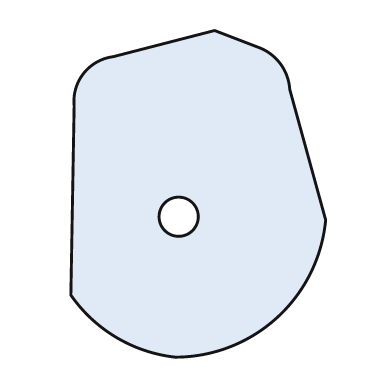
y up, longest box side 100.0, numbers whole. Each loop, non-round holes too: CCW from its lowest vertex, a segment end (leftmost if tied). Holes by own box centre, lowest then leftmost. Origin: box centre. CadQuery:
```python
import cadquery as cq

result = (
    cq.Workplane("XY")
    .moveTo(-7.0, -50.0)
    .threePointArc((24.0, -38.0), (39.0, -8.0))
    .lineTo(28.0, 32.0)
    .threePointArc((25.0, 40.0), (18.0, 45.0))
    .lineTo(5.0, 50.0)
    .lineTo(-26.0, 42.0)
    .threePointArc((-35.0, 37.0), (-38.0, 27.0))
    .lineTo(-39.0, -31.0)
    .threePointArc((-25.0, -44.0), (-7.0, -50.0))
    .close()
    .moveTo(-6.0, -7.0)
    .circle(6.0)
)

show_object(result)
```